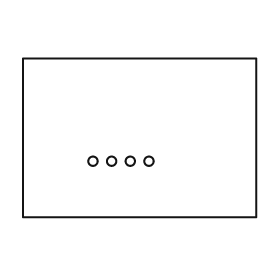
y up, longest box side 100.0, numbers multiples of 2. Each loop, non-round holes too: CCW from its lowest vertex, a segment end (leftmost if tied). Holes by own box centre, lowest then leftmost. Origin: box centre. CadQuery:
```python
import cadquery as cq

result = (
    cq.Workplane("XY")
    .moveTo(-50.0, -34.0)
    .lineTo(50.0, -34.0)
    .lineTo(50.0, 34.0)
    .lineTo(-50.0, 34.0)
    .close()
    .moveTo(-20.0, -10.0)
    .circle(2.0)
    .moveTo(-12.0, -10.0)
    .circle(2.0)
    .moveTo(-4.0, -10.0)
    .circle(2.0)
    .moveTo(4.0, -10.0)
    .circle(2.0)
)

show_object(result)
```